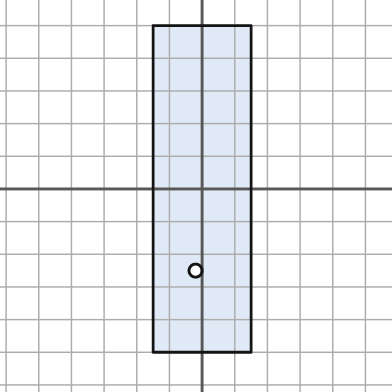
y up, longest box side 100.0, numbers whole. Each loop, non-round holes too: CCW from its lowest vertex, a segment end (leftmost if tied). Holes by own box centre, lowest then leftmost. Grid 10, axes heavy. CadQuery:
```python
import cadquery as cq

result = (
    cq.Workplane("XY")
    .moveTo(-15.0, -50.0)
    .lineTo(15.0, -50.0)
    .lineTo(15.0, 50.0)
    .lineTo(-15.0, 50.0)
    .close()
    .moveTo(-2.0, -25.0)
    .circle(2.0)
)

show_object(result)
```